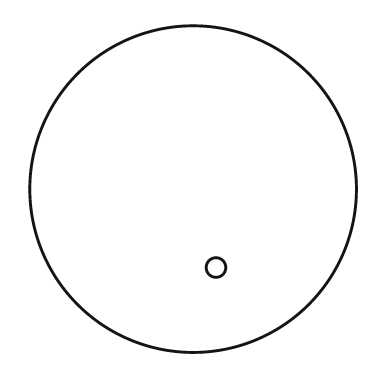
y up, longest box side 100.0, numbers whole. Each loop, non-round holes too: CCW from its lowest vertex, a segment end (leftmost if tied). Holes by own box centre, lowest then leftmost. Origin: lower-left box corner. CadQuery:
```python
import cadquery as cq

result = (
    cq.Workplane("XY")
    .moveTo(50.0, 50.0)
    .circle(50.0)
    .moveTo(57.0, 26.0)
    .circle(3.0)
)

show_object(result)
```